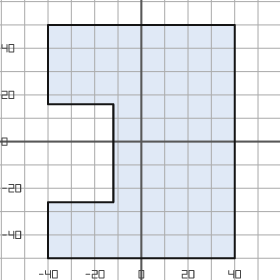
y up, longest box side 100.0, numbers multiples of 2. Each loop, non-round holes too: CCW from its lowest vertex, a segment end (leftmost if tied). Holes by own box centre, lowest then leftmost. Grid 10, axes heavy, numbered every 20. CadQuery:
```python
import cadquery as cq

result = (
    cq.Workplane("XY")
    .moveTo(-40.0, -50.0)
    .lineTo(40.0, -50.0)
    .lineTo(40.0, 50.0)
    .lineTo(-40.0, 50.0)
    .lineTo(-40.0, 16.0)
    .lineTo(-12.0, 16.0)
    .lineTo(-12.0, -26.0)
    .lineTo(-40.0, -26.0)
    .close()
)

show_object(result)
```